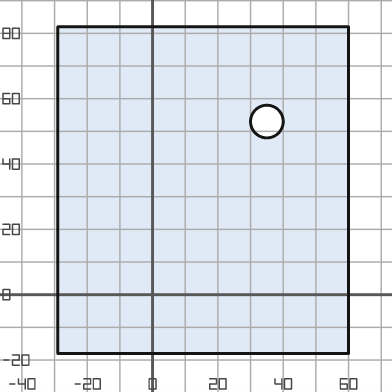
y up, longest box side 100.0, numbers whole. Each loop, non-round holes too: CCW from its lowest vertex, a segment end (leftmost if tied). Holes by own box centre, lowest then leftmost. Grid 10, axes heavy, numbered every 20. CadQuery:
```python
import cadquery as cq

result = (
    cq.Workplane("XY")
    .moveTo(-29.0, -18.0)
    .lineTo(60.0, -18.0)
    .lineTo(60.0, 82.0)
    .lineTo(-29.0, 82.0)
    .close()
    .moveTo(35.0, 53.0)
    .circle(5.0)
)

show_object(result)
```